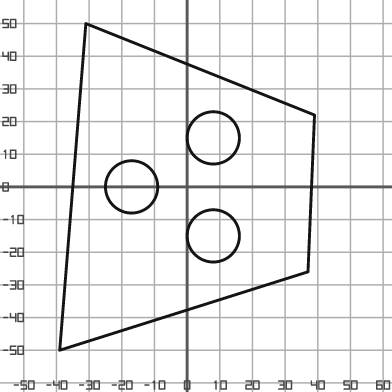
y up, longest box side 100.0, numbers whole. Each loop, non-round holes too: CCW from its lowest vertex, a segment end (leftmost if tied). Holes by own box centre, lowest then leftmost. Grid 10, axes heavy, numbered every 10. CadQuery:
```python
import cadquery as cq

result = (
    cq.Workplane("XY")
    .moveTo(-39.0, -50.0)
    .lineTo(37.0, -26.0)
    .lineTo(39.0, 22.0)
    .lineTo(-31.0, 50.0)
    .close()
    .moveTo(8.0, -15.0)
    .circle(8.0)
    .moveTo(-17.0, 0.0)
    .circle(8.0)
    .moveTo(8.0, 15.0)
    .circle(8.0)
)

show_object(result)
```